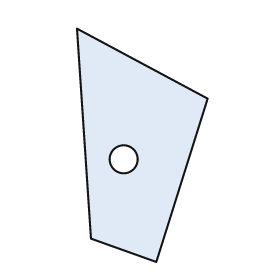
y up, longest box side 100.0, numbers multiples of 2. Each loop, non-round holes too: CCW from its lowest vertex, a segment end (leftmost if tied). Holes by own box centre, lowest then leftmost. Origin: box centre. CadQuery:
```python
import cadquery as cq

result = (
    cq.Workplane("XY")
    .moveTo(6.0, -50.0)
    .lineTo(28.0, 20.0)
    .lineTo(-28.0, 50.0)
    .lineTo(-22.0, -40.0)
    .close()
    .moveTo(-8.0, -6.0)
    .circle(6.0)
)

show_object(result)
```